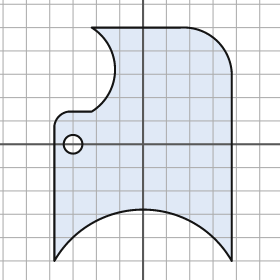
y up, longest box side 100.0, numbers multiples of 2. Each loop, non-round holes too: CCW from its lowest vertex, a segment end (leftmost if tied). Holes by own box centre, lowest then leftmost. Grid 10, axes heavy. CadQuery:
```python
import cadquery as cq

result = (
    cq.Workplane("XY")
    .moveTo(-38.0, -50.0)
    .threePointArc((0.0, -28.0), (38.0, -50.0))
    .lineTo(38.0, 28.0)
    .threePointArc((32.0, 44.0), (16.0, 50.0))
    .lineTo(-22.0, 50.0)
    .threePointArc((-12.0, 32.0), (-22.0, 14.0))
    .lineTo(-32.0, 14.0)
    .threePointArc((-36.0, 12.0), (-38.0, 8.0))
    .close()
    .moveTo(-30.0, 0.0)
    .circle(4.0)
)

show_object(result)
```